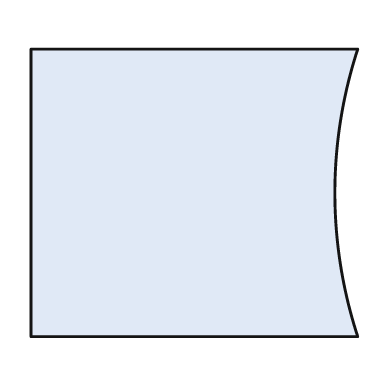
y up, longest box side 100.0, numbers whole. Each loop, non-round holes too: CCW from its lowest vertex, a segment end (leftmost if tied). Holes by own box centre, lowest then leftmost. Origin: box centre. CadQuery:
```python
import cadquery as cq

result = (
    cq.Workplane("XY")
    .moveTo(-50.0, -44.0)
    .lineTo(50.0, -44.0)
    .threePointArc((43.0, 0.0), (50.0, 44.0))
    .lineTo(-50.0, 44.0)
    .close()
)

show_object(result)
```